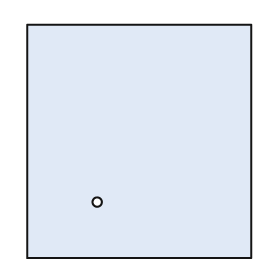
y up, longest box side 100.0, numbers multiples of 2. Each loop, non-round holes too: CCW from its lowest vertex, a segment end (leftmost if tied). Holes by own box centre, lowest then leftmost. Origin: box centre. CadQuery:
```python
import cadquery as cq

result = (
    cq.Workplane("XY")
    .moveTo(-48.0, -50.0)
    .lineTo(48.0, -50.0)
    .lineTo(48.0, 50.0)
    .lineTo(-48.0, 50.0)
    .close()
    .moveTo(-18.0, -26.0)
    .circle(2.0)
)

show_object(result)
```